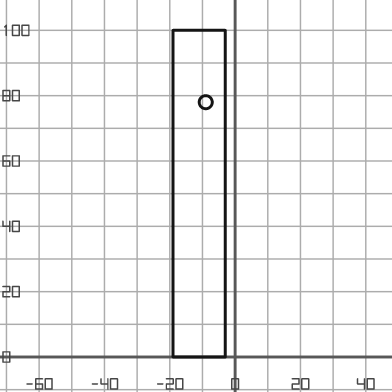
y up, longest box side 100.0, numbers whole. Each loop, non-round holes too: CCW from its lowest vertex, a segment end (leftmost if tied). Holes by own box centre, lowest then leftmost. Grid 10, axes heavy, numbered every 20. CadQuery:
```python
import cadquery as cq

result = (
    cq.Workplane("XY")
    .moveTo(-19.0, 0.0)
    .lineTo(-3.0, 0.0)
    .lineTo(-3.0, 100.0)
    .lineTo(-19.0, 100.0)
    .close()
    .moveTo(-9.0, 78.0)
    .circle(2.0)
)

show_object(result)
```